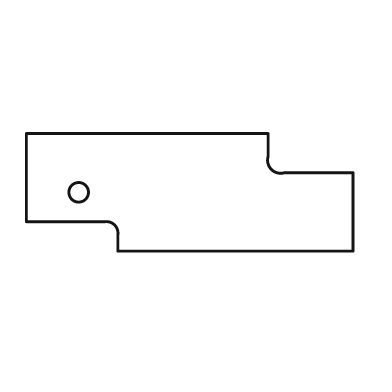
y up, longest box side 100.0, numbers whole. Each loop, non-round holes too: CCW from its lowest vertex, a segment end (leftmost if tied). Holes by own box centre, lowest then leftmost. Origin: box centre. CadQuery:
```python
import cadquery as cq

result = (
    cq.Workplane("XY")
    .moveTo(-22.0, -18.0)
    .lineTo(50.0, -18.0)
    .lineTo(50.0, 6.0)
    .lineTo(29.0, 6.0)
    .threePointArc((25.0, 7.0), (24.0, 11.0))
    .lineTo(24.0, 18.0)
    .lineTo(-50.0, 18.0)
    .lineTo(-50.0, -9.0)
    .lineTo(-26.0, -9.0)
    .threePointArc((-23.0, -10.0), (-22.0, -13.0))
    .close()
    .moveTo(-34.0, 0.0)
    .circle(3.0)
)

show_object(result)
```